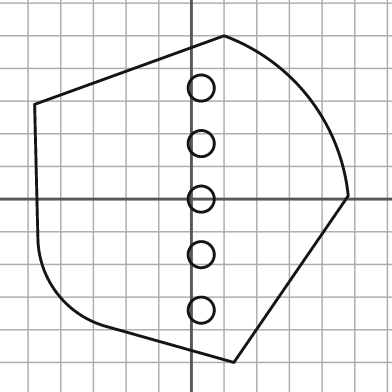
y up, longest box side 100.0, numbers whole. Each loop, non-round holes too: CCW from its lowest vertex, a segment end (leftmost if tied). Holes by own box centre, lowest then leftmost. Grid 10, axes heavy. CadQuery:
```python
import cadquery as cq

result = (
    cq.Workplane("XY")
    .moveTo(13.0, -50.0)
    .lineTo(48.0, 1.0)
    .threePointArc((36.0, 31.0), (10.0, 50.0))
    .lineTo(-48.0, 29.0)
    .lineTo(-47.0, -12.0)
    .threePointArc((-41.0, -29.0), (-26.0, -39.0))
    .close()
    .moveTo(3.0, -34.0)
    .circle(4.0)
    .moveTo(3.0, -17.0)
    .circle(4.0)
    .moveTo(3.0, 0.0)
    .circle(4.0)
    .moveTo(3.0, 17.0)
    .circle(4.0)
    .moveTo(3.0, 34.0)
    .circle(4.0)
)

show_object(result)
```